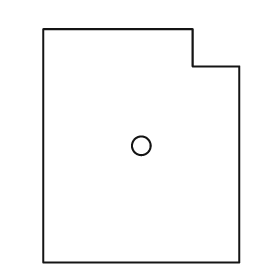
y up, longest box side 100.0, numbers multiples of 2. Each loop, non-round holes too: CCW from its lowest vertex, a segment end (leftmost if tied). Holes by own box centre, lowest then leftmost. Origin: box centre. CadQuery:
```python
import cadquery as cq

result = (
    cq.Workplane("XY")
    .moveTo(-42.0, -50.0)
    .lineTo(42.0, -50.0)
    .lineTo(42.0, 34.0)
    .lineTo(22.0, 34.0)
    .lineTo(22.0, 50.0)
    .lineTo(-42.0, 50.0)
    .close()
    .moveTo(0.0, 0.0)
    .circle(4.0)
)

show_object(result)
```